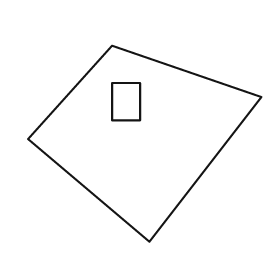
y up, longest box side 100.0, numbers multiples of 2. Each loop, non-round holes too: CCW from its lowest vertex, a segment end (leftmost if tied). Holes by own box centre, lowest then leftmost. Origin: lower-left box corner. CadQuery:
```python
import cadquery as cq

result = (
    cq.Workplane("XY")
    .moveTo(52.0, 0.0)
    .lineTo(100.0, 62.0)
    .lineTo(36.0, 84.0)
    .lineTo(0.0, 44.0)
    .close()
    .moveTo(36.0, 52.0)
    .lineTo(48.0, 52.0)
    .lineTo(48.0, 68.0)
    .lineTo(36.0, 68.0)
    .close()
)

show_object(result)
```